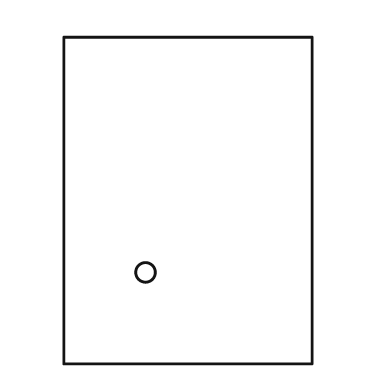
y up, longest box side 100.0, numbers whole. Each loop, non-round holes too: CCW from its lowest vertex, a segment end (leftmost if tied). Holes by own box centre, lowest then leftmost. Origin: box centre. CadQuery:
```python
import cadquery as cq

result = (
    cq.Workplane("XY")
    .moveTo(-38.0, -50.0)
    .lineTo(38.0, -50.0)
    .lineTo(38.0, 50.0)
    .lineTo(-38.0, 50.0)
    .close()
    .moveTo(-13.0, -22.0)
    .circle(3.0)
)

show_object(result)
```